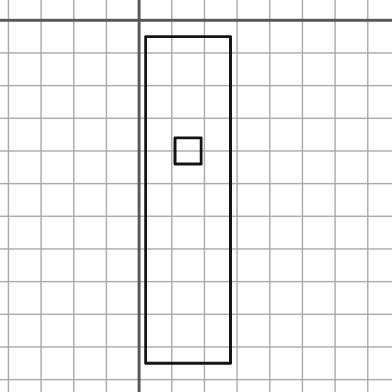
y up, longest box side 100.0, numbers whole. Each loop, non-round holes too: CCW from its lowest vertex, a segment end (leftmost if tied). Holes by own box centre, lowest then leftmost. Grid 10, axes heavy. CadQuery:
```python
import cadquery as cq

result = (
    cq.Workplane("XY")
    .moveTo(2.0, -105.0)
    .lineTo(28.0, -105.0)
    .lineTo(28.0, -5.0)
    .lineTo(2.0, -5.0)
    .close()
    .moveTo(11.0, -44.0)
    .lineTo(19.0, -44.0)
    .lineTo(19.0, -36.0)
    .lineTo(11.0, -36.0)
    .close()
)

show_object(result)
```